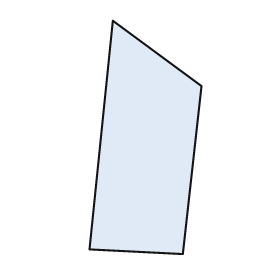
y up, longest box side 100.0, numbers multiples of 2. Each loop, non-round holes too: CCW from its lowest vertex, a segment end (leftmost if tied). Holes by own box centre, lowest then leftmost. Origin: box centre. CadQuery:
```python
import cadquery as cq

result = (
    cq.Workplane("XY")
    .moveTo(16.0, -50.0)
    .lineTo(24.0, 22.0)
    .lineTo(-14.0, 50.0)
    .lineTo(-24.0, -48.0)
    .close()
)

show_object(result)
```